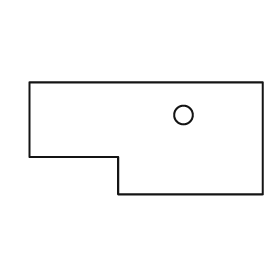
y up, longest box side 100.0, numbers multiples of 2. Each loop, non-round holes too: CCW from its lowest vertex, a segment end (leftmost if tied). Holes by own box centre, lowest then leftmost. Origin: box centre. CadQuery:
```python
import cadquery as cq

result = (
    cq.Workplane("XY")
    .moveTo(-12.0, -24.0)
    .lineTo(50.0, -24.0)
    .lineTo(50.0, 24.0)
    .lineTo(-50.0, 24.0)
    .lineTo(-50.0, -8.0)
    .lineTo(-12.0, -8.0)
    .close()
    .moveTo(16.0, 10.0)
    .circle(4.0)
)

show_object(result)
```